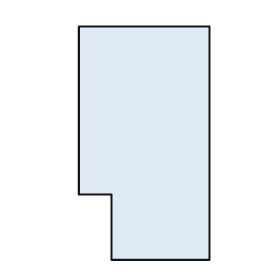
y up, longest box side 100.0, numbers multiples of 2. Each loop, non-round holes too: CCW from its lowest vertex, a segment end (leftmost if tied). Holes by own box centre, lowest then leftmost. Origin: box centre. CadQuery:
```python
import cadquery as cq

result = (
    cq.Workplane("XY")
    .moveTo(-14.0, -50.0)
    .lineTo(28.0, -50.0)
    .lineTo(28.0, 50.0)
    .lineTo(-28.0, 50.0)
    .lineTo(-28.0, -22.0)
    .lineTo(-14.0, -22.0)
    .close()
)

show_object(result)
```